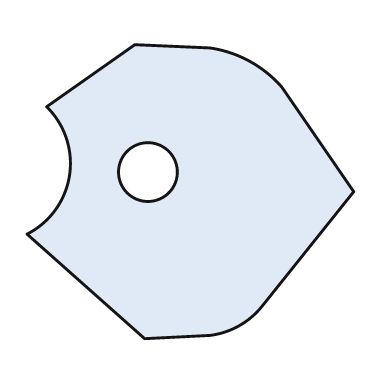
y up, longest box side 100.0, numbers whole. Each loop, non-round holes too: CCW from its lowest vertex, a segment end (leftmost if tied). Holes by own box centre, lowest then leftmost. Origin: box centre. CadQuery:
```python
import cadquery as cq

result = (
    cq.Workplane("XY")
    .moveTo(-14.0, -45.0)
    .lineTo(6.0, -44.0)
    .threePointArc((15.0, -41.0), (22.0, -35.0))
    .lineTo(50.0, 0.0)
    .lineTo(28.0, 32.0)
    .threePointArc((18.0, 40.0), (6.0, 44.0))
    .lineTo(-17.0, 45.0)
    .lineTo(-44.0, 26.0)
    .threePointArc((-37.0, 5.0), (-50.0, -13.0))
    .close()
    .moveTo(-13.0, 6.0)
    .circle(9.0)
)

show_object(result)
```